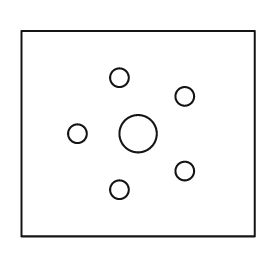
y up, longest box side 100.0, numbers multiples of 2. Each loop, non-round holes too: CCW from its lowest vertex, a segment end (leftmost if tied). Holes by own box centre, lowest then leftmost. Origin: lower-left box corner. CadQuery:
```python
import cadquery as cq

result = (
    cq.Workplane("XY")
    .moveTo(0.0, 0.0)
    .lineTo(100.0, 0.0)
    .lineTo(100.0, 88.0)
    .lineTo(0.0, 88.0)
    .close()
    .moveTo(42.0, 20.0)
    .circle(4.0)
    .moveTo(70.0, 28.0)
    .circle(4.0)
    .moveTo(24.0, 44.0)
    .circle(4.0)
    .moveTo(50.0, 44.0)
    .circle(8.0)
    .moveTo(70.0, 60.0)
    .circle(4.0)
    .moveTo(42.0, 68.0)
    .circle(4.0)
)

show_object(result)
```